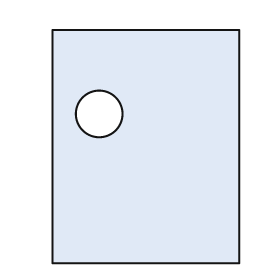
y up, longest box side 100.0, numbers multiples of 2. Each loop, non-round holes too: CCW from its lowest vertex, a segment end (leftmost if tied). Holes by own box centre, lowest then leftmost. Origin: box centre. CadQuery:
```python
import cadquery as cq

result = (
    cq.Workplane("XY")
    .moveTo(-40.0, -50.0)
    .lineTo(40.0, -50.0)
    .lineTo(40.0, 50.0)
    .lineTo(-40.0, 50.0)
    .close()
    .moveTo(-20.0, 14.0)
    .circle(10.0)
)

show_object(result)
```